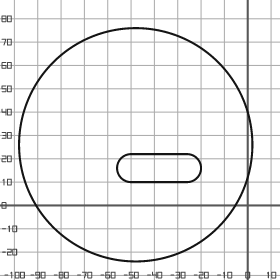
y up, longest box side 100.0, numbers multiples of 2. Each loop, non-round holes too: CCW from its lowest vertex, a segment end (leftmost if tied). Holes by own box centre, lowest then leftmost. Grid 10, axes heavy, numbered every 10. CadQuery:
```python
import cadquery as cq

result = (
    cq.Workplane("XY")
    .moveTo(-48.0, 26.0)
    .circle(50.0)
    .moveTo(-50.0, 10.0)
    .lineTo(-26.0, 10.0)
    .threePointArc((-20.0, 16.0), (-26.0, 22.0))
    .lineTo(-50.0, 22.0)
    .threePointArc((-56.0, 16.0), (-50.0, 10.0))
    .close()
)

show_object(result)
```